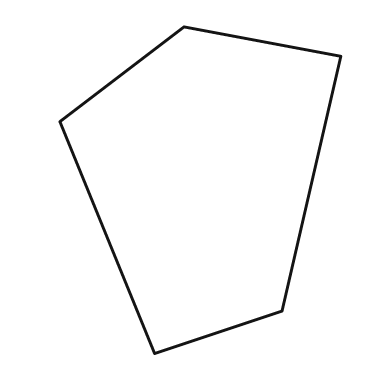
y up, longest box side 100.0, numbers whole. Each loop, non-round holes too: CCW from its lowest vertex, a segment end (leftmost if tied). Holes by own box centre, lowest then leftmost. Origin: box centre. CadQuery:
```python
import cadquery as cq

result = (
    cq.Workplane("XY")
    .moveTo(-14.0, -50.0)
    .lineTo(25.0, -37.0)
    .lineTo(43.0, 41.0)
    .lineTo(-5.0, 50.0)
    .lineTo(-43.0, 21.0)
    .close()
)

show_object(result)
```